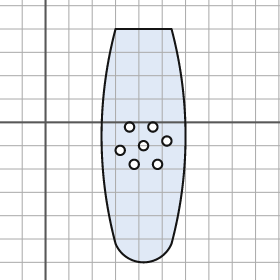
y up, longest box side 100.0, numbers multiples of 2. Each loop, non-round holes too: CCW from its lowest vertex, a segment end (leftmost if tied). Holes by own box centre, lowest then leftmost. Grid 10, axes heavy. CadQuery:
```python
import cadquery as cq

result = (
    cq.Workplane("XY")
    .moveTo(30.0, -52.0)
    .threePointArc((42.0, -60.0), (54.0, -52.0))
    .threePointArc((60.0, -6.0), (54.0, 40.0))
    .lineTo(30.0, 40.0)
    .threePointArc((24.0, -6.0), (30.0, -52.0))
    .close()
    .moveTo(38.0, -18.0)
    .circle(2.0)
    .moveTo(48.0, -18.0)
    .circle(2.0)
    .moveTo(32.0, -12.0)
    .circle(2.0)
    .moveTo(42.0, -10.0)
    .circle(2.0)
    .moveTo(52.0, -8.0)
    .circle(2.0)
    .moveTo(36.0, -2.0)
    .circle(2.0)
    .moveTo(46.0, -2.0)
    .circle(2.0)
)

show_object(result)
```